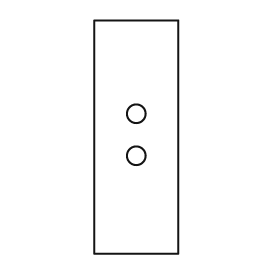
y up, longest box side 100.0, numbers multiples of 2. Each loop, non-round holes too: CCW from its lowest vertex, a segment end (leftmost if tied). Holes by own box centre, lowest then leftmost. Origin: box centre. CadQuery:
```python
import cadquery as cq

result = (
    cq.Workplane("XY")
    .moveTo(-18.0, -50.0)
    .lineTo(18.0, -50.0)
    .lineTo(18.0, 50.0)
    .lineTo(-18.0, 50.0)
    .close()
    .moveTo(0.0, -8.0)
    .circle(4.0)
    .moveTo(0.0, 10.0)
    .circle(4.0)
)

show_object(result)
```